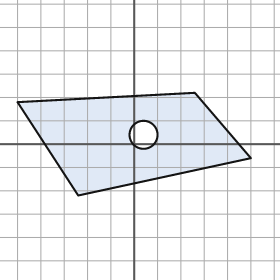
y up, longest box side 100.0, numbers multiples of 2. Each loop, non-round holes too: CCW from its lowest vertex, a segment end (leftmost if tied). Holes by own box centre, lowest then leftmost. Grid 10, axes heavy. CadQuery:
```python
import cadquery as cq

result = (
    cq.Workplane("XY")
    .moveTo(-24.0, -22.0)
    .lineTo(50.0, -6.0)
    .lineTo(26.0, 22.0)
    .lineTo(-50.0, 18.0)
    .close()
    .moveTo(4.0, 4.0)
    .circle(6.0)
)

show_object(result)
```